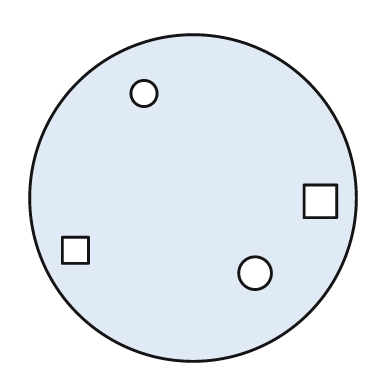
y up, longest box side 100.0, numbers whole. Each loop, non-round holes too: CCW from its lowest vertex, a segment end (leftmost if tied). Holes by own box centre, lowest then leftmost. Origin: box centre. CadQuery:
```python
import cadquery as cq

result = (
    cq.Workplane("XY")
    .moveTo(0.0, 0.0)
    .circle(50.0)
    .moveTo(19.0, -23.0)
    .circle(5.0)
    .moveTo(-40.0, -20.0)
    .lineTo(-32.0, -20.0)
    .lineTo(-32.0, -12.0)
    .lineTo(-40.0, -12.0)
    .close()
    .moveTo(34.0, -6.0)
    .lineTo(44.0, -6.0)
    .lineTo(44.0, 4.0)
    .lineTo(34.0, 4.0)
    .close()
    .moveTo(-15.0, 32.0)
    .circle(4.0)
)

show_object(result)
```